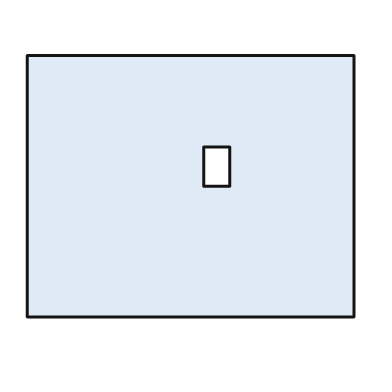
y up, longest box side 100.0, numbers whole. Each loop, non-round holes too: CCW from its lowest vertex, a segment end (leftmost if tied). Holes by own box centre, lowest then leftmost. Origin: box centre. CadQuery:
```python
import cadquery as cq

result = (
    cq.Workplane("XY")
    .moveTo(-50.0, -40.0)
    .lineTo(50.0, -40.0)
    .lineTo(50.0, 40.0)
    .lineTo(-50.0, 40.0)
    .close()
    .moveTo(4.0, 0.0)
    .lineTo(12.0, 0.0)
    .lineTo(12.0, 12.0)
    .lineTo(4.0, 12.0)
    .close()
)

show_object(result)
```